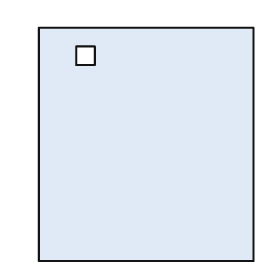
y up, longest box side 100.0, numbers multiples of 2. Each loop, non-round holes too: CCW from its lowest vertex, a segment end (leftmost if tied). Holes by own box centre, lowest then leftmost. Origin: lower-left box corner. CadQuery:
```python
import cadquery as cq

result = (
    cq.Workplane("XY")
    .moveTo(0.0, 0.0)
    .lineTo(92.0, 0.0)
    .lineTo(92.0, 100.0)
    .lineTo(0.0, 100.0)
    .close()
    .moveTo(16.0, 84.0)
    .lineTo(24.0, 84.0)
    .lineTo(24.0, 92.0)
    .lineTo(16.0, 92.0)
    .close()
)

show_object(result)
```